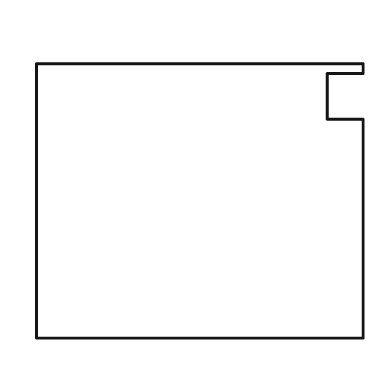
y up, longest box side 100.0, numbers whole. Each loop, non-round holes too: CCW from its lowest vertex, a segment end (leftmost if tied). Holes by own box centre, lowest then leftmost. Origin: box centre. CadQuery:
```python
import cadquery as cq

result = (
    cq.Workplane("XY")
    .moveTo(-50.0, -42.0)
    .lineTo(50.0, -42.0)
    .lineTo(50.0, 25.0)
    .lineTo(39.0, 25.0)
    .lineTo(39.0, 39.0)
    .lineTo(50.0, 39.0)
    .lineTo(50.0, 42.0)
    .lineTo(-50.0, 42.0)
    .close()
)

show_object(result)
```